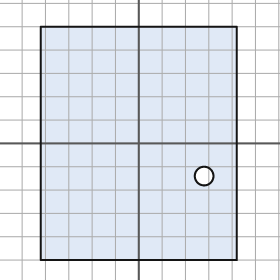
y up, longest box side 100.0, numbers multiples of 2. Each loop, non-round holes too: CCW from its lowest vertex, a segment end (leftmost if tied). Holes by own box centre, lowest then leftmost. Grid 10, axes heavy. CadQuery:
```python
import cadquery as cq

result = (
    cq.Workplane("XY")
    .moveTo(-42.0, -50.0)
    .lineTo(42.0, -50.0)
    .lineTo(42.0, 50.0)
    .lineTo(-42.0, 50.0)
    .close()
    .moveTo(28.0, -14.0)
    .circle(4.0)
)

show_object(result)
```